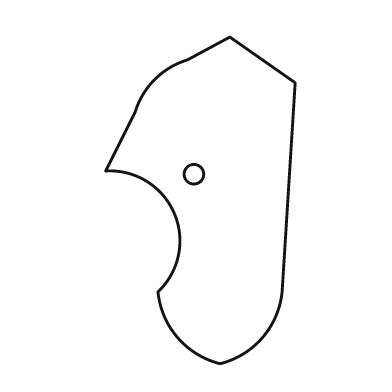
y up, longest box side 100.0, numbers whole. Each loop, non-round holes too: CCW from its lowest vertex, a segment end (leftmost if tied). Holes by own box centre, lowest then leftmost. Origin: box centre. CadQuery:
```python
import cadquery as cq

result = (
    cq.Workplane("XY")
    .moveTo(6.0, -50.0)
    .threePointArc((19.0, -42.0), (25.0, -28.0))
    .lineTo(29.0, 36.0)
    .lineTo(9.0, 50.0)
    .lineTo(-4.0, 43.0)
    .threePointArc((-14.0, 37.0), (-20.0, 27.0))
    .lineTo(-29.0, 9.0)
    .threePointArc((-8.0, -4.0), (-13.0, -28.0))
    .threePointArc((-7.0, -42.0), (6.0, -50.0))
    .close()
    .moveTo(-2.0, 8.0)
    .circle(3.0)
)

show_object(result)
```